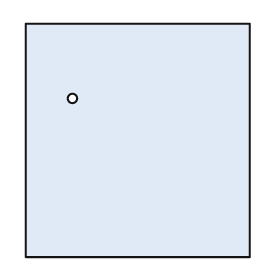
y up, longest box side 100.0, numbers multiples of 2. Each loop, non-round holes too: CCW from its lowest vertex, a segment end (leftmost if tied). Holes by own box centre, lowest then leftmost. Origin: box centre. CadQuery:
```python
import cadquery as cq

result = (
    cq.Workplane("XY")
    .moveTo(-48.0, -50.0)
    .lineTo(48.0, -50.0)
    .lineTo(48.0, 50.0)
    .lineTo(-48.0, 50.0)
    .close()
    .moveTo(-28.0, 18.0)
    .circle(2.0)
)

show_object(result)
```